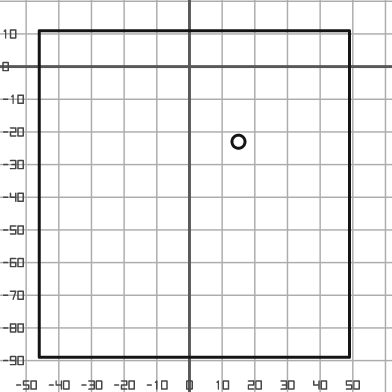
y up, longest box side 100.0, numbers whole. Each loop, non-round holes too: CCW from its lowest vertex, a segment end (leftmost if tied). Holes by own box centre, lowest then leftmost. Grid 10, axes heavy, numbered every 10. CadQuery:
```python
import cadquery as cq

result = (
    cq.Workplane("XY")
    .moveTo(-46.0, -89.0)
    .lineTo(49.0, -89.0)
    .lineTo(49.0, 11.0)
    .lineTo(-46.0, 11.0)
    .close()
    .moveTo(15.0, -23.0)
    .circle(2.0)
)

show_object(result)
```